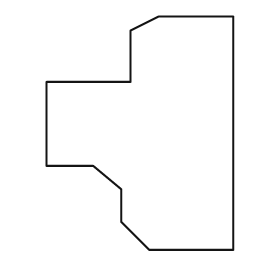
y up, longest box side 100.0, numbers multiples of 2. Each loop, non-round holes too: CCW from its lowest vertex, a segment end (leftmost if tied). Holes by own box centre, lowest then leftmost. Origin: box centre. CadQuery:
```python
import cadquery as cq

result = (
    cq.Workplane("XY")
    .moveTo(4.0, -50.0)
    .lineTo(40.0, -50.0)
    .lineTo(40.0, 50.0)
    .lineTo(8.0, 50.0)
    .lineTo(-4.0, 44.0)
    .lineTo(-4.0, 22.0)
    .lineTo(-40.0, 22.0)
    .lineTo(-40.0, -14.0)
    .lineTo(-20.0, -14.0)
    .lineTo(-8.0, -24.0)
    .lineTo(-8.0, -38.0)
    .close()
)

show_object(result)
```